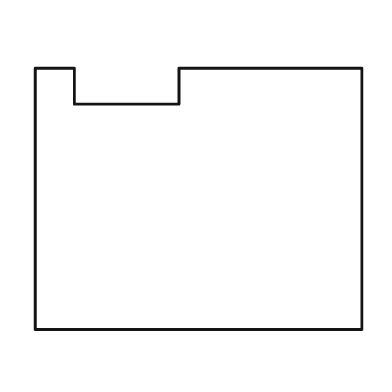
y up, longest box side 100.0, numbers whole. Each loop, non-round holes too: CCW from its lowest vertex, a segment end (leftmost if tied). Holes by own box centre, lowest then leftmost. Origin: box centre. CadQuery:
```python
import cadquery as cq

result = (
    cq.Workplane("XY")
    .moveTo(-50.0, -40.0)
    .lineTo(50.0, -40.0)
    .lineTo(50.0, 40.0)
    .lineTo(-6.0, 40.0)
    .lineTo(-6.0, 29.0)
    .lineTo(-38.0, 29.0)
    .lineTo(-38.0, 40.0)
    .lineTo(-50.0, 40.0)
    .close()
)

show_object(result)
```